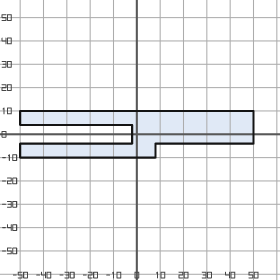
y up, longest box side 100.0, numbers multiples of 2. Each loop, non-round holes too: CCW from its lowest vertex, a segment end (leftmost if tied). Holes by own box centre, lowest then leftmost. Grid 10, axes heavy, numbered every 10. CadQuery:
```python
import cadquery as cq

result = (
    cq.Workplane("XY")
    .moveTo(-50.0, -10.0)
    .lineTo(8.0, -10.0)
    .lineTo(8.0, -4.0)
    .lineTo(50.0, -4.0)
    .lineTo(50.0, 10.0)
    .lineTo(-50.0, 10.0)
    .lineTo(-50.0, 4.0)
    .lineTo(-2.0, 4.0)
    .lineTo(-2.0, -4.0)
    .lineTo(-50.0, -4.0)
    .close()
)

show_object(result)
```